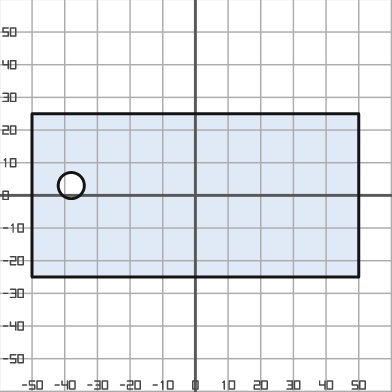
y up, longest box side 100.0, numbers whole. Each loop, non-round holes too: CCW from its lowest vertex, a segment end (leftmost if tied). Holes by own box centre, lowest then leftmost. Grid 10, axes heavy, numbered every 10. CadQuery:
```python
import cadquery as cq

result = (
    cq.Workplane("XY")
    .moveTo(-50.0, -25.0)
    .lineTo(50.0, -25.0)
    .lineTo(50.0, 25.0)
    .lineTo(-50.0, 25.0)
    .close()
    .moveTo(-38.0, 3.0)
    .circle(4.0)
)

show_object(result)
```